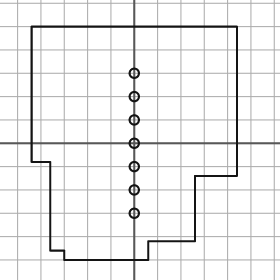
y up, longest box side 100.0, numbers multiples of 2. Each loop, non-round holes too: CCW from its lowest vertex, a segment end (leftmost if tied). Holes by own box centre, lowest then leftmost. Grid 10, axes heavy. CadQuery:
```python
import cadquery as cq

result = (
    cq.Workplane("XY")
    .moveTo(-30.0, -50.0)
    .lineTo(6.0, -50.0)
    .lineTo(6.0, -42.0)
    .lineTo(26.0, -42.0)
    .lineTo(26.0, -14.0)
    .lineTo(44.0, -14.0)
    .lineTo(44.0, 50.0)
    .lineTo(-44.0, 50.0)
    .lineTo(-44.0, -8.0)
    .lineTo(-36.0, -8.0)
    .lineTo(-36.0, -46.0)
    .lineTo(-30.0, -46.0)
    .close()
    .moveTo(0.0, -30.0)
    .circle(2.0)
    .moveTo(0.0, -20.0)
    .circle(2.0)
    .moveTo(0.0, -10.0)
    .circle(2.0)
    .moveTo(0.0, 0.0)
    .circle(2.0)
    .moveTo(0.0, 10.0)
    .circle(2.0)
    .moveTo(0.0, 20.0)
    .circle(2.0)
    .moveTo(0.0, 30.0)
    .circle(2.0)
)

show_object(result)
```